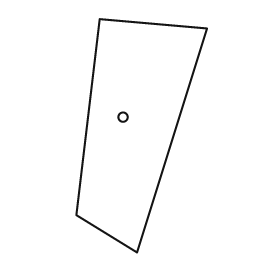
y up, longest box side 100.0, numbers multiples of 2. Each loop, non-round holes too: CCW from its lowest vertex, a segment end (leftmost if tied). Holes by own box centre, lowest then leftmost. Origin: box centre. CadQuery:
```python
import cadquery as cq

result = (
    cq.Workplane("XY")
    .moveTo(-2.0, -50.0)
    .lineTo(28.0, 46.0)
    .lineTo(-18.0, 50.0)
    .lineTo(-28.0, -34.0)
    .close()
    .moveTo(-8.0, 8.0)
    .circle(2.0)
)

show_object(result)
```